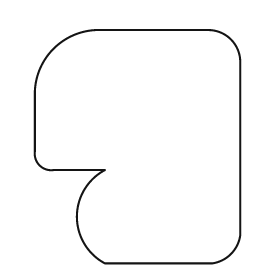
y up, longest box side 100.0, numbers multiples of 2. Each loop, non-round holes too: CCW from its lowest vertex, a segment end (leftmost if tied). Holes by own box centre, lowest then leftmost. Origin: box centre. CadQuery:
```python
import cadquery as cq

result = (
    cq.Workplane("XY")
    .moveTo(-14.0, -50.0)
    .lineTo(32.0, -50.0)
    .threePointArc((40.0, -46.0), (44.0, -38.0))
    .lineTo(44.0, 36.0)
    .threePointArc((40.0, 46.0), (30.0, 50.0))
    .lineTo(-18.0, 50.0)
    .threePointArc((-36.0, 42.0), (-44.0, 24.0))
    .lineTo(-44.0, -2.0)
    .threePointArc((-42.0, -8.0), (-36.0, -10.0))
    .lineTo(-14.0, -10.0)
    .threePointArc((-26.0, -30.0), (-14.0, -50.0))
    .close()
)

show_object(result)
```